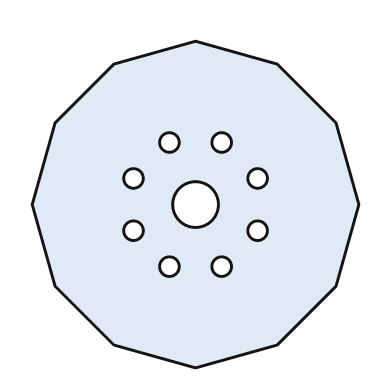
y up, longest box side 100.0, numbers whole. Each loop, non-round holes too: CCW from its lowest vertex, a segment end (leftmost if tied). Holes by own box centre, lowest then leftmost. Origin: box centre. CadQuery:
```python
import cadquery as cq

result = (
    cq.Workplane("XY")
    .moveTo(0.0, -50.0)
    .lineTo(25.0, -43.0)
    .lineTo(43.0, -25.0)
    .lineTo(50.0, 0.0)
    .lineTo(43.0, 25.0)
    .lineTo(25.0, 43.0)
    .lineTo(0.0, 50.0)
    .lineTo(-25.0, 43.0)
    .lineTo(-43.0, 25.0)
    .lineTo(-50.0, 0.0)
    .lineTo(-43.0, -25.0)
    .lineTo(-25.0, -43.0)
    .close()
    .moveTo(-8.0, -19.0)
    .circle(3.0)
    .moveTo(8.0, -19.0)
    .circle(3.0)
    .moveTo(-19.0, -8.0)
    .circle(3.0)
    .moveTo(19.0, -8.0)
    .circle(3.0)
    .moveTo(0.0, 0.0)
    .circle(7.0)
    .moveTo(-19.0, 8.0)
    .circle(3.0)
    .moveTo(19.0, 8.0)
    .circle(3.0)
    .moveTo(-8.0, 19.0)
    .circle(3.0)
    .moveTo(8.0, 19.0)
    .circle(3.0)
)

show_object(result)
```